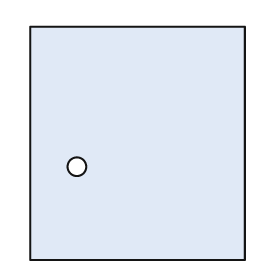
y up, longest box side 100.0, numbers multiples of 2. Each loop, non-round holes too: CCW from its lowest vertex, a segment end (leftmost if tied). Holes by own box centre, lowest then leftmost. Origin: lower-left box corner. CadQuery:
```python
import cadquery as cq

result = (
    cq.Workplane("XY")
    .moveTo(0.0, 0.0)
    .lineTo(92.0, 0.0)
    .lineTo(92.0, 100.0)
    .lineTo(0.0, 100.0)
    .close()
    .moveTo(20.0, 40.0)
    .circle(4.0)
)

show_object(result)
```